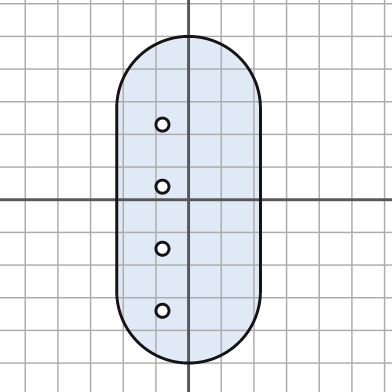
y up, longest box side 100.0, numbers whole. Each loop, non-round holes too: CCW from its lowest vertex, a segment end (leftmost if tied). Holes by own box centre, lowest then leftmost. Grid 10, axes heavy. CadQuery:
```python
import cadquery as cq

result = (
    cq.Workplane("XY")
    .moveTo(-22.0, -28.0)
    .threePointArc((0.0, -50.0), (22.0, -28.0))
    .lineTo(22.0, 28.0)
    .threePointArc((0.0, 50.0), (-22.0, 28.0))
    .close()
    .moveTo(-8.0, -34.0)
    .circle(2.0)
    .moveTo(-8.0, -15.0)
    .circle(2.0)
    .moveTo(-8.0, 4.0)
    .circle(2.0)
    .moveTo(-8.0, 23.0)
    .circle(2.0)
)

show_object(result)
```